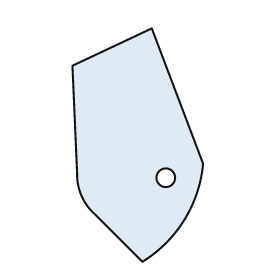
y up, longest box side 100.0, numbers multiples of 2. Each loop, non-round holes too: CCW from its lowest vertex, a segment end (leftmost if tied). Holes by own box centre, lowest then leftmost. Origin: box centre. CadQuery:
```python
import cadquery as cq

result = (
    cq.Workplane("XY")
    .moveTo(2.0, -50.0)
    .threePointArc((20.0, -32.0), (28.0, -8.0))
    .lineTo(6.0, 50.0)
    .lineTo(-28.0, 34.0)
    .lineTo(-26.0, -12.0)
    .threePointArc((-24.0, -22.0), (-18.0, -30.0))
    .close()
    .moveTo(12.0, -14.0)
    .circle(4.0)
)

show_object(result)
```